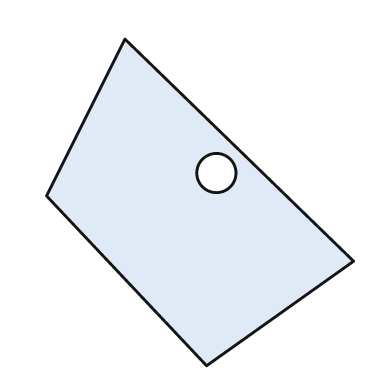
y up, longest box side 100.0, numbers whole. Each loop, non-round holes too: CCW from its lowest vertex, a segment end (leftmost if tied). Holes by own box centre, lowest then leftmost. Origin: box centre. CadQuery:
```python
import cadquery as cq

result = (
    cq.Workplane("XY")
    .moveTo(2.0, -50.0)
    .lineTo(47.0, -18.0)
    .lineTo(-23.0, 50.0)
    .lineTo(-47.0, 2.0)
    .close()
    .moveTo(5.0, 9.0)
    .circle(6.0)
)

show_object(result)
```